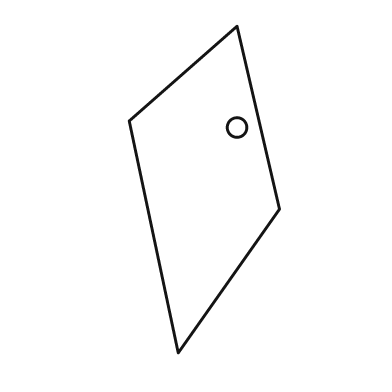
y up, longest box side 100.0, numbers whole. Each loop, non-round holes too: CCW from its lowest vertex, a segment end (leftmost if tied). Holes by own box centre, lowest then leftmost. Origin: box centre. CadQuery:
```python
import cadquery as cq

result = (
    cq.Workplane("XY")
    .moveTo(-8.0, -50.0)
    .lineTo(23.0, -6.0)
    .lineTo(10.0, 50.0)
    .lineTo(-23.0, 21.0)
    .close()
    .moveTo(10.0, 19.0)
    .circle(3.0)
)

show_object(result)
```